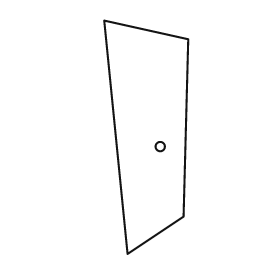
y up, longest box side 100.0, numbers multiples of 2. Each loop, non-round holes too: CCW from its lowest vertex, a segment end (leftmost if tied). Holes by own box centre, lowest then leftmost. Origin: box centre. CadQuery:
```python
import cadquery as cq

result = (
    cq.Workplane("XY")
    .moveTo(-8.0, -50.0)
    .lineTo(16.0, -34.0)
    .lineTo(18.0, 42.0)
    .lineTo(-18.0, 50.0)
    .close()
    .moveTo(6.0, -4.0)
    .circle(2.0)
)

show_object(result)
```